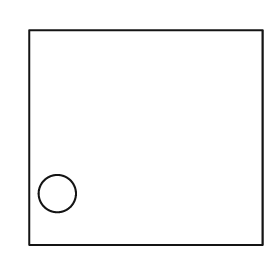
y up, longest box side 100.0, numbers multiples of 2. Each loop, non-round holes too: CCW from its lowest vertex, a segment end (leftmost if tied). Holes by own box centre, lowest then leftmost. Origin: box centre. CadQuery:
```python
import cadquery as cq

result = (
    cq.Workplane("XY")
    .moveTo(-50.0, -46.0)
    .lineTo(50.0, -46.0)
    .lineTo(50.0, 46.0)
    .lineTo(-50.0, 46.0)
    .close()
    .moveTo(-38.0, -24.0)
    .circle(8.0)
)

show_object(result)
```